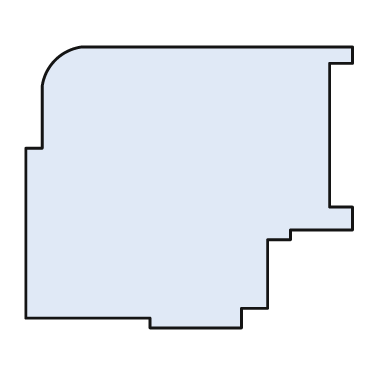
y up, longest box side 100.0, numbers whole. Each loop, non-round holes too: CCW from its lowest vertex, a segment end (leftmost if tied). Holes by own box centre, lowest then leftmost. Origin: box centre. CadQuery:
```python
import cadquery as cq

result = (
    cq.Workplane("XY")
    .moveTo(-12.0, -43.0)
    .lineTo(16.0, -43.0)
    .lineTo(16.0, -37.0)
    .lineTo(24.0, -37.0)
    .lineTo(24.0, -16.0)
    .lineTo(31.0, -16.0)
    .lineTo(31.0, -13.0)
    .lineTo(50.0, -13.0)
    .lineTo(50.0, -6.0)
    .lineTo(43.0, -6.0)
    .lineTo(43.0, 38.0)
    .lineTo(50.0, 38.0)
    .lineTo(50.0, 43.0)
    .lineTo(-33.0, 43.0)
    .threePointArc((-41.0, 39.0), (-45.0, 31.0))
    .lineTo(-45.0, 12.0)
    .lineTo(-50.0, 12.0)
    .lineTo(-50.0, -40.0)
    .lineTo(-12.0, -40.0)
    .close()
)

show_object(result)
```